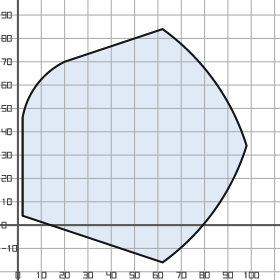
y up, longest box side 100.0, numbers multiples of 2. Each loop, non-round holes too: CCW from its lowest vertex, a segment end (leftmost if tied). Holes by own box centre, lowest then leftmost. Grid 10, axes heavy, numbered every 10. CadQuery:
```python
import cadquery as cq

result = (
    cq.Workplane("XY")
    .moveTo(62.0, -16.0)
    .threePointArc((84.0, 6.0), (98.0, 34.0))
    .threePointArc((84.0, 62.0), (62.0, 84.0))
    .lineTo(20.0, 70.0)
    .threePointArc((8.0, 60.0), (2.0, 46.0))
    .lineTo(2.0, 4.0)
    .close()
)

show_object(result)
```